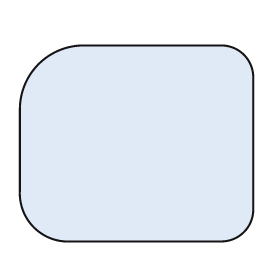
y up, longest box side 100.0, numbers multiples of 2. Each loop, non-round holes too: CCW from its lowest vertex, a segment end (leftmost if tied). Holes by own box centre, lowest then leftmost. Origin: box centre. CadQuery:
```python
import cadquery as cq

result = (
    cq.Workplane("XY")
    .moveTo(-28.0, -42.0)
    .lineTo(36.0, -42.0)
    .threePointArc((46.0, -38.0), (50.0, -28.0))
    .lineTo(50.0, 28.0)
    .threePointArc((46.0, 38.0), (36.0, 42.0))
    .lineTo(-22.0, 42.0)
    .threePointArc((-42.0, 34.0), (-50.0, 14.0))
    .lineTo(-50.0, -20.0)
    .threePointArc((-44.0, -36.0), (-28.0, -42.0))
    .close()
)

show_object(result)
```